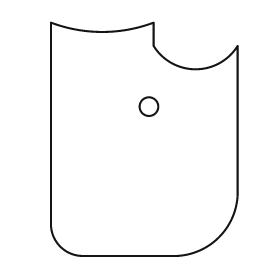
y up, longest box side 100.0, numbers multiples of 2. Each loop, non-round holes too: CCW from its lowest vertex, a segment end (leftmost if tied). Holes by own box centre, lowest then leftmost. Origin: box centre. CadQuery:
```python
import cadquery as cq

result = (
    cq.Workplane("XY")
    .moveTo(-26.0, -50.0)
    .lineTo(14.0, -50.0)
    .threePointArc((32.0, -42.0), (40.0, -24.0))
    .lineTo(40.0, 40.0)
    .threePointArc((22.0, 30.0), (4.0, 40.0))
    .lineTo(4.0, 50.0)
    .threePointArc((-18.0, 46.0), (-40.0, 50.0))
    .lineTo(-40.0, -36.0)
    .threePointArc((-36.0, -46.0), (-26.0, -50.0))
    .close()
    .moveTo(2.0, 14.0)
    .circle(4.0)
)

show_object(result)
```